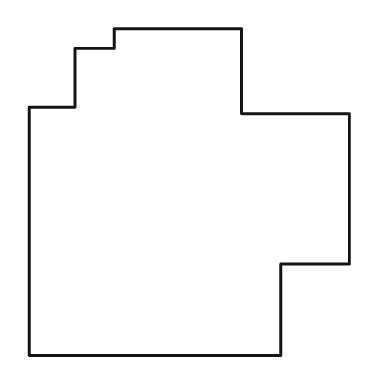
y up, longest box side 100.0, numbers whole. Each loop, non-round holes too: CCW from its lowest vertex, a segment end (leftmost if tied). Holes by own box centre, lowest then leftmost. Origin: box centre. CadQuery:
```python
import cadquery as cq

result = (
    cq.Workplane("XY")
    .moveTo(-49.0, -50.0)
    .lineTo(28.0, -50.0)
    .lineTo(28.0, -22.0)
    .lineTo(49.0, -22.0)
    .lineTo(49.0, 24.0)
    .lineTo(16.0, 24.0)
    .lineTo(16.0, 50.0)
    .lineTo(-23.0, 50.0)
    .lineTo(-23.0, 44.0)
    .lineTo(-35.0, 44.0)
    .lineTo(-35.0, 26.0)
    .lineTo(-49.0, 26.0)
    .close()
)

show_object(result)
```